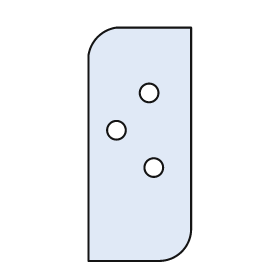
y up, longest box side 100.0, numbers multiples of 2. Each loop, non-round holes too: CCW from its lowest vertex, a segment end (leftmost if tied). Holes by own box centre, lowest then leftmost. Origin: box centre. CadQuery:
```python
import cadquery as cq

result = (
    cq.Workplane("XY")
    .moveTo(-22.0, -50.0)
    .lineTo(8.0, -50.0)
    .threePointArc((18.0, -46.0), (22.0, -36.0))
    .lineTo(22.0, 50.0)
    .lineTo(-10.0, 50.0)
    .threePointArc((-18.0, 46.0), (-22.0, 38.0))
    .close()
    .moveTo(6.0, -10.0)
    .circle(4.0)
    .moveTo(-10.0, 6.0)
    .circle(4.0)
    .moveTo(4.0, 22.0)
    .circle(4.0)
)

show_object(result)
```